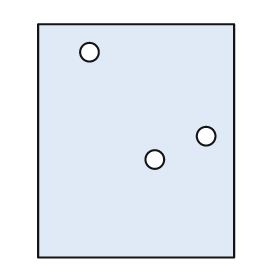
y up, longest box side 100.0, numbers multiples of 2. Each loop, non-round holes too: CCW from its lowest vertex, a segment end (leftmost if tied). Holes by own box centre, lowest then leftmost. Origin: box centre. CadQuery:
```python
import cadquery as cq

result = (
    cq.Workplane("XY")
    .moveTo(-42.0, -50.0)
    .lineTo(42.0, -50.0)
    .lineTo(42.0, 50.0)
    .lineTo(-42.0, 50.0)
    .close()
    .moveTo(8.0, -8.0)
    .circle(4.0)
    .moveTo(30.0, 2.0)
    .circle(4.0)
    .moveTo(-20.0, 38.0)
    .circle(4.0)
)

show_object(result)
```